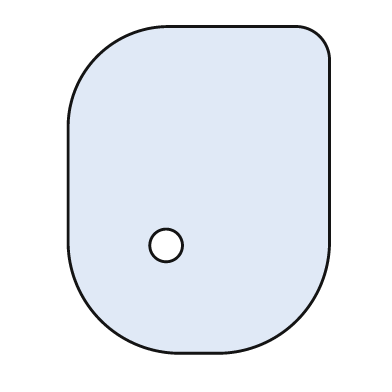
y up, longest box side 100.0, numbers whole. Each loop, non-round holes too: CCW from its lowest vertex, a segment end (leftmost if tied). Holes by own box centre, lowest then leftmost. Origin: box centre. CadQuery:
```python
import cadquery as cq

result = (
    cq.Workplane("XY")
    .moveTo(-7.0, -50.0)
    .lineTo(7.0, -50.0)
    .threePointArc((30.0, -40.0), (40.0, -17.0))
    .lineTo(40.0, 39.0)
    .threePointArc((37.0, 47.0), (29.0, 50.0))
    .lineTo(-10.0, 50.0)
    .threePointArc((-31.0, 41.0), (-40.0, 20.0))
    .lineTo(-40.0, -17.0)
    .threePointArc((-30.0, -40.0), (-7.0, -50.0))
    .close()
    .moveTo(-10.0, -17.0)
    .circle(5.0)
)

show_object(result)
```